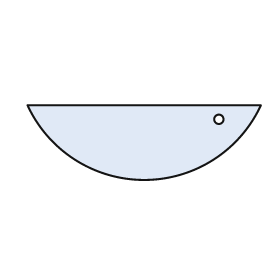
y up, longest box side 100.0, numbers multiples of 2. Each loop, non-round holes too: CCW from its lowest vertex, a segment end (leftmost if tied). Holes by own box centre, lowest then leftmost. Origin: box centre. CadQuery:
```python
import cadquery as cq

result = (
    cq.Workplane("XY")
    .moveTo(-50.0, 16.0)
    .threePointArc((0.0, -16.0), (50.0, 16.0))
    .close()
    .moveTo(32.0, 10.0)
    .circle(2.0)
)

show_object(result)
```